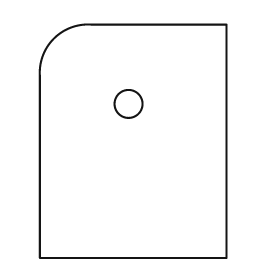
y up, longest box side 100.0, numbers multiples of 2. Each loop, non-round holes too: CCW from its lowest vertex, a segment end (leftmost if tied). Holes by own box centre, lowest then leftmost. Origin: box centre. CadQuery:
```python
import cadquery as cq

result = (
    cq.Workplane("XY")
    .moveTo(-40.0, -50.0)
    .lineTo(40.0, -50.0)
    .lineTo(40.0, 50.0)
    .lineTo(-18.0, 50.0)
    .threePointArc((-34.0, 44.0), (-40.0, 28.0))
    .close()
    .moveTo(-2.0, 16.0)
    .circle(6.0)
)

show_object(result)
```